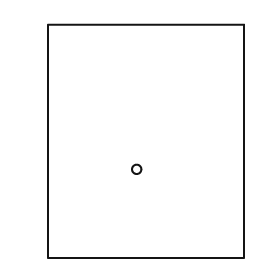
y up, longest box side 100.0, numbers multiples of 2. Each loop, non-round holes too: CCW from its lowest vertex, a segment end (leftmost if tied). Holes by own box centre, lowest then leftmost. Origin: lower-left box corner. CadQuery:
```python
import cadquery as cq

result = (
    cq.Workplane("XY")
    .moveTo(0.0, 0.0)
    .lineTo(84.0, 0.0)
    .lineTo(84.0, 100.0)
    .lineTo(0.0, 100.0)
    .close()
    .moveTo(38.0, 38.0)
    .circle(2.0)
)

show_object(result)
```